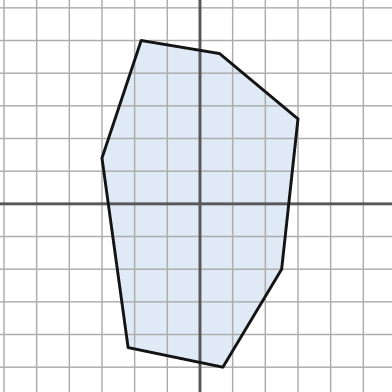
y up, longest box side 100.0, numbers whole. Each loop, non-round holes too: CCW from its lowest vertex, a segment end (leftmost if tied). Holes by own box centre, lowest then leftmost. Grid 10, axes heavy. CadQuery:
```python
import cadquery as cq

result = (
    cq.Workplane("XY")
    .moveTo(7.0, -50.0)
    .lineTo(25.0, -20.0)
    .lineTo(30.0, 26.0)
    .lineTo(6.0, 46.0)
    .lineTo(-18.0, 50.0)
    .lineTo(-30.0, 14.0)
    .lineTo(-22.0, -44.0)
    .close()
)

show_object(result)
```